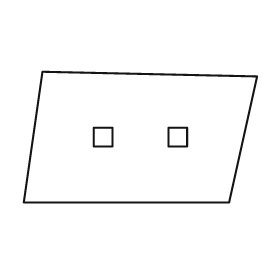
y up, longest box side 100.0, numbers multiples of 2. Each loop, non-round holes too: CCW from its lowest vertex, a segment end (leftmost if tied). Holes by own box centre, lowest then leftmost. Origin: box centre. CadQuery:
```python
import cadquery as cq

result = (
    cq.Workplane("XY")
    .moveTo(-50.0, -28.0)
    .lineTo(38.0, -28.0)
    .lineTo(50.0, 26.0)
    .lineTo(-42.0, 28.0)
    .close()
    .moveTo(-20.0, -4.0)
    .lineTo(-12.0, -4.0)
    .lineTo(-12.0, 4.0)
    .lineTo(-20.0, 4.0)
    .close()
    .moveTo(12.0, -4.0)
    .lineTo(20.0, -4.0)
    .lineTo(20.0, 4.0)
    .lineTo(12.0, 4.0)
    .close()
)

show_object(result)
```